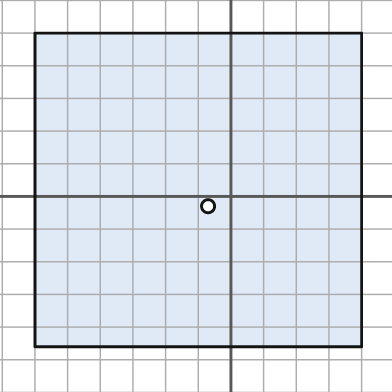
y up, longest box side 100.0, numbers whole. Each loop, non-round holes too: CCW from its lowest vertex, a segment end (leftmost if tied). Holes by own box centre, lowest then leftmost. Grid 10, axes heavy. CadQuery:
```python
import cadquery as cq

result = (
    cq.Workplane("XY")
    .moveTo(-60.0, -46.0)
    .lineTo(40.0, -46.0)
    .lineTo(40.0, 50.0)
    .lineTo(-60.0, 50.0)
    .close()
    .moveTo(-7.0, -3.0)
    .circle(2.0)
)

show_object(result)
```